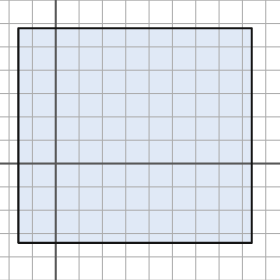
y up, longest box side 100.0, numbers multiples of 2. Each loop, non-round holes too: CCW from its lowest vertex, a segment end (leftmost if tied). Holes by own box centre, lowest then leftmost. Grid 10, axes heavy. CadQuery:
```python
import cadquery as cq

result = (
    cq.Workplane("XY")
    .moveTo(-16.0, -34.0)
    .lineTo(84.0, -34.0)
    .lineTo(84.0, 58.0)
    .lineTo(-16.0, 58.0)
    .close()
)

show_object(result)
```